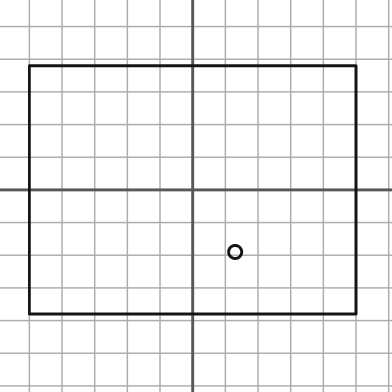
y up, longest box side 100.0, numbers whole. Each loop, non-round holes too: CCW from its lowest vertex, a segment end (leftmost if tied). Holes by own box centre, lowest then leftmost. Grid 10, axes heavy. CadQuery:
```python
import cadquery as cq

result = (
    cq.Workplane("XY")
    .moveTo(-50.0, -38.0)
    .lineTo(50.0, -38.0)
    .lineTo(50.0, 38.0)
    .lineTo(-50.0, 38.0)
    .close()
    .moveTo(13.0, -19.0)
    .circle(2.0)
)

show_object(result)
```